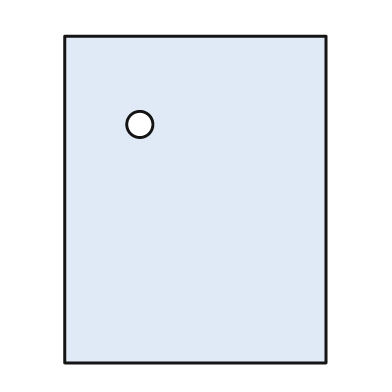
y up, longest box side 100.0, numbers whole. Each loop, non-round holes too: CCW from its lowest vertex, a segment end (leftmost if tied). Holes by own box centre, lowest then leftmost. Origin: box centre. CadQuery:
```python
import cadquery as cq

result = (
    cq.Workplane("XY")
    .moveTo(-40.0, -50.0)
    .lineTo(40.0, -50.0)
    .lineTo(40.0, 50.0)
    .lineTo(-40.0, 50.0)
    .close()
    .moveTo(-17.0, 23.0)
    .circle(4.0)
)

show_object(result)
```